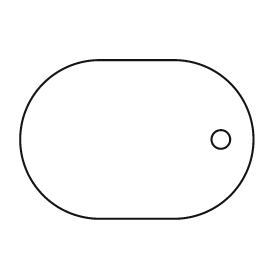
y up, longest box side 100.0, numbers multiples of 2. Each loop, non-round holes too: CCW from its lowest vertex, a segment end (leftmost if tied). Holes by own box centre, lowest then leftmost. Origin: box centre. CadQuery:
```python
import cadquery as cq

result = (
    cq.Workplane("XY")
    .moveTo(-16.0, -34.0)
    .lineTo(16.0, -34.0)
    .threePointArc((50.0, 0.0), (16.0, 34.0))
    .lineTo(-16.0, 34.0)
    .threePointArc((-50.0, 0.0), (-16.0, -34.0))
    .close()
    .moveTo(36.0, 0.0)
    .circle(4.0)
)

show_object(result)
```